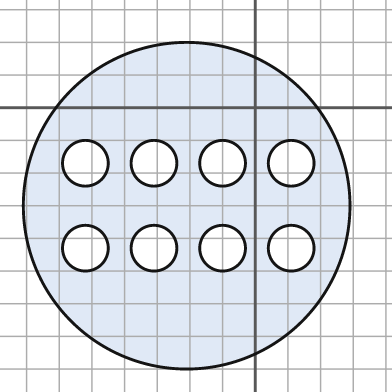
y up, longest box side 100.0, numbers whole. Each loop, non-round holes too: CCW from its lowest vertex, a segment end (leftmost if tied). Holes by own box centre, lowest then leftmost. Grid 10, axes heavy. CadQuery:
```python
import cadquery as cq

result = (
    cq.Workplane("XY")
    .moveTo(-21.0, -30.0)
    .circle(50.0)
    .moveTo(-52.0, -43.0)
    .circle(7.0)
    .moveTo(-31.0, -43.0)
    .circle(7.0)
    .moveTo(-10.0, -43.0)
    .circle(7.0)
    .moveTo(11.0, -43.0)
    .circle(7.0)
    .moveTo(-52.0, -17.0)
    .circle(7.0)
    .moveTo(-31.0, -17.0)
    .circle(7.0)
    .moveTo(-10.0, -17.0)
    .circle(7.0)
    .moveTo(11.0, -17.0)
    .circle(7.0)
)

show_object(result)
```